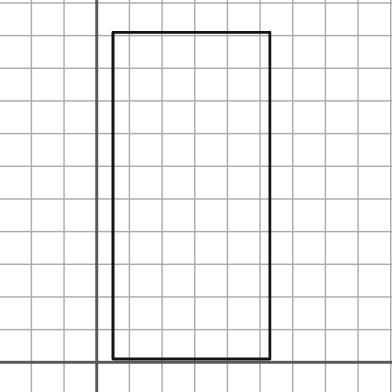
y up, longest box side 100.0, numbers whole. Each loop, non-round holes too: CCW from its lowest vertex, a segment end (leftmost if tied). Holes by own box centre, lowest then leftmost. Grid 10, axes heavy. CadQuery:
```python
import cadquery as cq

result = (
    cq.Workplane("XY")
    .moveTo(5.0, 1.0)
    .lineTo(53.0, 1.0)
    .lineTo(53.0, 101.0)
    .lineTo(5.0, 101.0)
    .close()
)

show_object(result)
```